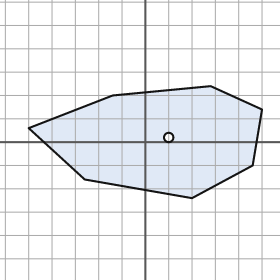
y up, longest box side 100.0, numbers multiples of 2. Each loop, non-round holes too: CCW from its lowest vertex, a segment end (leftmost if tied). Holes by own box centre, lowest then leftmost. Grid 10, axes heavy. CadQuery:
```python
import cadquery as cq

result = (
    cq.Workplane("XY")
    .moveTo(20.0, -24.0)
    .lineTo(46.0, -10.0)
    .lineTo(50.0, 14.0)
    .lineTo(28.0, 24.0)
    .lineTo(-14.0, 20.0)
    .lineTo(-50.0, 6.0)
    .lineTo(-26.0, -16.0)
    .close()
    .moveTo(10.0, 2.0)
    .circle(2.0)
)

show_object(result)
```